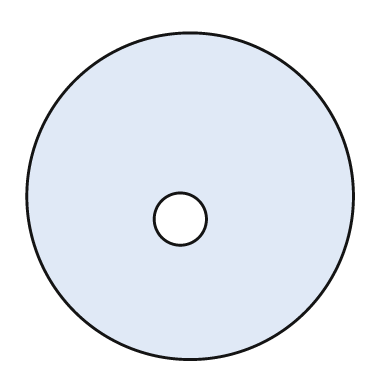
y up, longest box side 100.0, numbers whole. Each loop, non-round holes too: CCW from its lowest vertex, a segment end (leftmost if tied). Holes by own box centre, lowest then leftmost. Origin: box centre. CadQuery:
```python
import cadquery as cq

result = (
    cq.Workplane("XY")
    .moveTo(0.0, 0.0)
    .circle(50.0)
    .moveTo(-3.0, -7.0)
    .circle(8.0)
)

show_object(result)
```